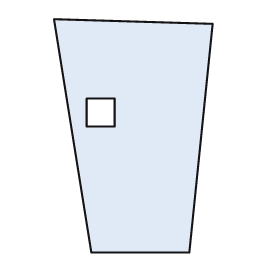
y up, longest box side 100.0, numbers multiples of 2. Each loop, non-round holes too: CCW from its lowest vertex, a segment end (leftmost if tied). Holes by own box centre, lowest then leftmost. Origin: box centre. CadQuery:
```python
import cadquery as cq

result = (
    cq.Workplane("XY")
    .moveTo(-18.0, -50.0)
    .lineTo(24.0, -50.0)
    .lineTo(34.0, 48.0)
    .lineTo(-34.0, 50.0)
    .close()
    .moveTo(-20.0, 4.0)
    .lineTo(-8.0, 4.0)
    .lineTo(-8.0, 16.0)
    .lineTo(-20.0, 16.0)
    .close()
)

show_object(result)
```